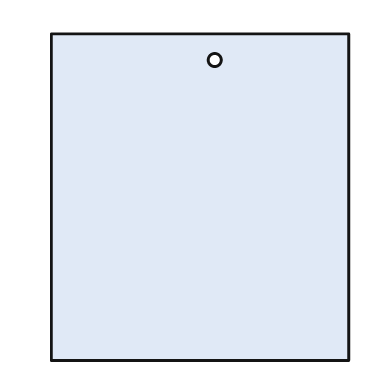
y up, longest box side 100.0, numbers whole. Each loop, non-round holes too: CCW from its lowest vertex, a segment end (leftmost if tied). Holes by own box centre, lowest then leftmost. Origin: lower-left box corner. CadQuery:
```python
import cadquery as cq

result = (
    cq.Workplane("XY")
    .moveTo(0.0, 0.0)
    .lineTo(91.0, 0.0)
    .lineTo(91.0, 100.0)
    .lineTo(0.0, 100.0)
    .close()
    .moveTo(50.0, 92.0)
    .circle(2.0)
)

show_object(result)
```